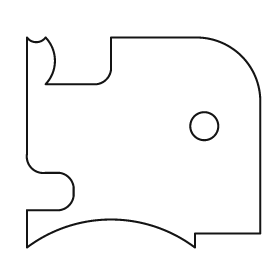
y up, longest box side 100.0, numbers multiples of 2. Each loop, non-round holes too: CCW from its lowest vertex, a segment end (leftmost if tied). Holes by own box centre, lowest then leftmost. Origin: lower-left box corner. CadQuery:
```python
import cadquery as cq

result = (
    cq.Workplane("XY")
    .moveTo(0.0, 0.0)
    .threePointArc((36.0, 12.0), (72.0, 0.0))
    .lineTo(72.0, 6.0)
    .lineTo(100.0, 6.0)
    .lineTo(100.0, 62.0)
    .threePointArc((92.0, 82.0), (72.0, 90.0))
    .lineTo(36.0, 90.0)
    .lineTo(36.0, 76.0)
    .threePointArc((34.0, 72.0), (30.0, 70.0))
    .lineTo(8.0, 70.0)
    .threePointArc((12.0, 80.0), (8.0, 90.0))
    .threePointArc((4.0, 88.0), (0.0, 90.0))
    .lineTo(0.0, 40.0)
    .threePointArc((2.0, 34.0), (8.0, 32.0))
    .lineTo(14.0, 32.0)
    .threePointArc((18.0, 30.0), (20.0, 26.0))
    .lineTo(20.0, 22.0)
    .threePointArc((18.0, 18.0), (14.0, 16.0))
    .lineTo(0.0, 16.0)
    .close()
    .moveTo(76.0, 52.0)
    .circle(6.0)
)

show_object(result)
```